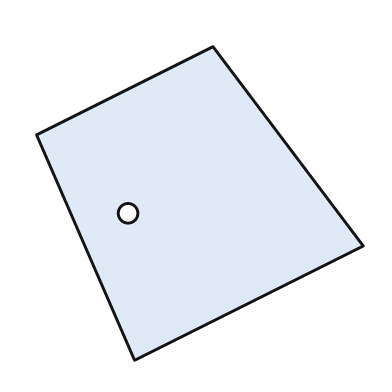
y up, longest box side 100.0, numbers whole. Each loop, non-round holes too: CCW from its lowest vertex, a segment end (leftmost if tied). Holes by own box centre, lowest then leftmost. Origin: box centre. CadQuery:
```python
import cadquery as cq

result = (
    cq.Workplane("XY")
    .moveTo(-20.0, -48.0)
    .lineTo(50.0, -13.0)
    .lineTo(4.0, 48.0)
    .lineTo(-50.0, 21.0)
    .close()
    .moveTo(-22.0, -3.0)
    .circle(3.0)
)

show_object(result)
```